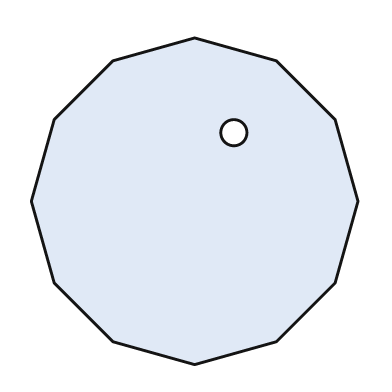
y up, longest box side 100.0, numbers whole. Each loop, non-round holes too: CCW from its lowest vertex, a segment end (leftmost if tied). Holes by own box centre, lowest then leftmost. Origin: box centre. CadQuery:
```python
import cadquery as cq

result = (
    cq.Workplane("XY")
    .moveTo(0.0, -50.0)
    .lineTo(25.0, -43.0)
    .lineTo(43.0, -25.0)
    .lineTo(50.0, 0.0)
    .lineTo(43.0, 25.0)
    .lineTo(25.0, 43.0)
    .lineTo(0.0, 50.0)
    .lineTo(-25.0, 43.0)
    .lineTo(-43.0, 25.0)
    .lineTo(-50.0, 0.0)
    .lineTo(-43.0, -25.0)
    .lineTo(-25.0, -43.0)
    .close()
    .moveTo(12.0, 21.0)
    .circle(4.0)
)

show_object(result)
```